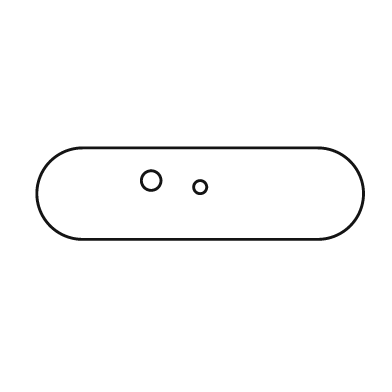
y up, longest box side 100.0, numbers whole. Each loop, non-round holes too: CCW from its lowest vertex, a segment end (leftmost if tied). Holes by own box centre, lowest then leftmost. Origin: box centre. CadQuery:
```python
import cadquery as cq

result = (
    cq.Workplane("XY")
    .moveTo(-36.0, -14.0)
    .lineTo(36.0, -14.0)
    .threePointArc((50.0, 0.0), (36.0, 14.0))
    .lineTo(-36.0, 14.0)
    .threePointArc((-50.0, 0.0), (-36.0, -14.0))
    .close()
    .moveTo(0.0, 2.0)
    .circle(2.0)
    .moveTo(-15.0, 4.0)
    .circle(3.0)
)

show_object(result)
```